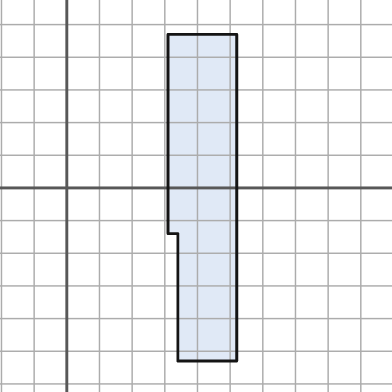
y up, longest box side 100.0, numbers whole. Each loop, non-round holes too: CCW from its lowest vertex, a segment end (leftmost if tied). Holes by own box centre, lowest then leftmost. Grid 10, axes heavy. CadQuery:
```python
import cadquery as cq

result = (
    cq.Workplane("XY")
    .moveTo(34.0, -53.0)
    .lineTo(52.0, -53.0)
    .lineTo(52.0, 47.0)
    .lineTo(31.0, 47.0)
    .lineTo(31.0, -14.0)
    .lineTo(34.0, -14.0)
    .close()
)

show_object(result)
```